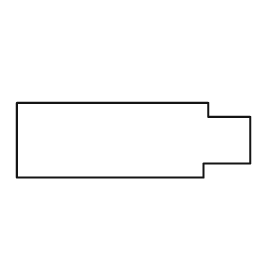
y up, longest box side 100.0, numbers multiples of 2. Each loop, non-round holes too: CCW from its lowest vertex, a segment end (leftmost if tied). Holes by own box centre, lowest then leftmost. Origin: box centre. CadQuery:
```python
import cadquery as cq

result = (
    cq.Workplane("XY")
    .moveTo(-50.0, -16.0)
    .lineTo(30.0, -16.0)
    .lineTo(30.0, -10.0)
    .lineTo(50.0, -10.0)
    .lineTo(50.0, 10.0)
    .lineTo(32.0, 10.0)
    .lineTo(32.0, 16.0)
    .lineTo(-50.0, 16.0)
    .close()
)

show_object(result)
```